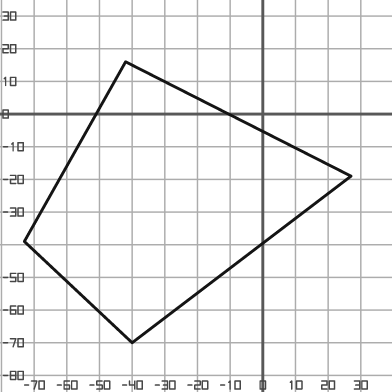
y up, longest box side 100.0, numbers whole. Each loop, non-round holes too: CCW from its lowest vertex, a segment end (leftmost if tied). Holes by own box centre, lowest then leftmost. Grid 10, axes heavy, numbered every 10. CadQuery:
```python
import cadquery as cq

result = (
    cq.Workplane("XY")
    .moveTo(-40.0, -70.0)
    .lineTo(27.0, -19.0)
    .lineTo(-42.0, 16.0)
    .lineTo(-73.0, -39.0)
    .close()
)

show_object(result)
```